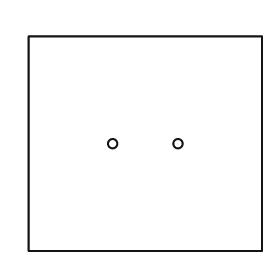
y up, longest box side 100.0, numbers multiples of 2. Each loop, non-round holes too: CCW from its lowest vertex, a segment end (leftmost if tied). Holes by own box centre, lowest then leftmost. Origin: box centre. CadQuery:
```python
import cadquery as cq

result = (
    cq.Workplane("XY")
    .moveTo(-50.0, -46.0)
    .lineTo(50.0, -46.0)
    .lineTo(50.0, 46.0)
    .lineTo(-50.0, 46.0)
    .close()
    .moveTo(-14.0, 0.0)
    .circle(2.0)
    .moveTo(14.0, 0.0)
    .circle(2.0)
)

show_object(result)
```